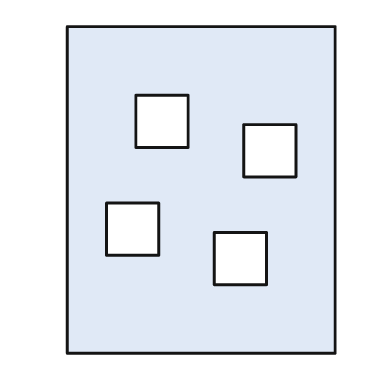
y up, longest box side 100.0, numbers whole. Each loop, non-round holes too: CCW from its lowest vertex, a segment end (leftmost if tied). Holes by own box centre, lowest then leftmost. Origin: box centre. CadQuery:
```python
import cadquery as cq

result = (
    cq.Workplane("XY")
    .moveTo(-41.0, -50.0)
    .lineTo(41.0, -50.0)
    .lineTo(41.0, 50.0)
    .lineTo(-41.0, 50.0)
    .close()
    .moveTo(4.0, -29.0)
    .lineTo(20.0, -29.0)
    .lineTo(20.0, -13.0)
    .lineTo(4.0, -13.0)
    .close()
    .moveTo(-29.0, -20.0)
    .lineTo(-13.0, -20.0)
    .lineTo(-13.0, -4.0)
    .lineTo(-29.0, -4.0)
    .close()
    .moveTo(13.0, 4.0)
    .lineTo(29.0, 4.0)
    .lineTo(29.0, 20.0)
    .lineTo(13.0, 20.0)
    .close()
    .moveTo(-20.0, 13.0)
    .lineTo(-4.0, 13.0)
    .lineTo(-4.0, 29.0)
    .lineTo(-20.0, 29.0)
    .close()
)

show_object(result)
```